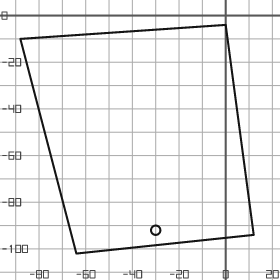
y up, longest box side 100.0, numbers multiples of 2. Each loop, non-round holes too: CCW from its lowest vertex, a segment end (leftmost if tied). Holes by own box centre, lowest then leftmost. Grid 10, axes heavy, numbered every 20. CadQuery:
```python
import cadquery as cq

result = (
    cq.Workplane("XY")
    .moveTo(-64.0, -102.0)
    .lineTo(12.0, -94.0)
    .lineTo(0.0, -4.0)
    .lineTo(-88.0, -10.0)
    .close()
    .moveTo(-30.0, -92.0)
    .circle(2.0)
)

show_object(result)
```